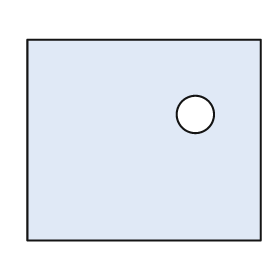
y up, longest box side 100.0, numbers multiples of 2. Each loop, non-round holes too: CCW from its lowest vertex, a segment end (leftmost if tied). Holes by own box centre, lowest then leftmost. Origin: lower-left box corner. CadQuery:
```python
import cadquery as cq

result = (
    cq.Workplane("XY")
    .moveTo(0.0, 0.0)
    .lineTo(100.0, 0.0)
    .lineTo(100.0, 86.0)
    .lineTo(0.0, 86.0)
    .close()
    .moveTo(72.0, 54.0)
    .circle(8.0)
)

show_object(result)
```